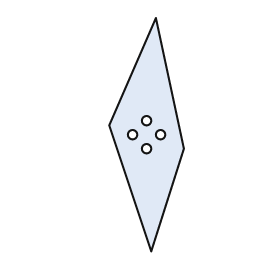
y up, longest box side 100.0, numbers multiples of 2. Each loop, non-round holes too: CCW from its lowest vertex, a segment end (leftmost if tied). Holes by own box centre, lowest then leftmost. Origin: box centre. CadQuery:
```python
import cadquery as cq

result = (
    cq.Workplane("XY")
    .moveTo(2.0, -50.0)
    .lineTo(16.0, -6.0)
    .lineTo(4.0, 50.0)
    .lineTo(-16.0, 4.0)
    .close()
    .moveTo(0.0, -6.0)
    .circle(2.0)
    .moveTo(-6.0, 0.0)
    .circle(2.0)
    .moveTo(6.0, 0.0)
    .circle(2.0)
    .moveTo(0.0, 6.0)
    .circle(2.0)
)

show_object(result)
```